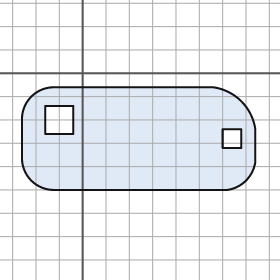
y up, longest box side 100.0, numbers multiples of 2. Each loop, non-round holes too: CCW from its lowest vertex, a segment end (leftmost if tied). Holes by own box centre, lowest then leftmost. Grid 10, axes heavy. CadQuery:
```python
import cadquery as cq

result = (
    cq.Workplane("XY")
    .moveTo(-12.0, -50.0)
    .lineTo(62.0, -50.0)
    .threePointArc((70.0, -46.0), (74.0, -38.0))
    .lineTo(74.0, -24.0)
    .threePointArc((68.0, -12.0), (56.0, -6.0))
    .lineTo(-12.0, -6.0)
    .threePointArc((-22.0, -10.0), (-26.0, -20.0))
    .lineTo(-26.0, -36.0)
    .threePointArc((-22.0, -46.0), (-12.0, -50.0))
    .close()
    .moveTo(60.0, -32.0)
    .lineTo(68.0, -32.0)
    .lineTo(68.0, -24.0)
    .lineTo(60.0, -24.0)
    .close()
    .moveTo(-16.0, -26.0)
    .lineTo(-4.0, -26.0)
    .lineTo(-4.0, -14.0)
    .lineTo(-16.0, -14.0)
    .close()
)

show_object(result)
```